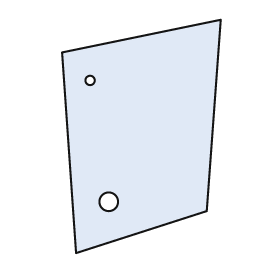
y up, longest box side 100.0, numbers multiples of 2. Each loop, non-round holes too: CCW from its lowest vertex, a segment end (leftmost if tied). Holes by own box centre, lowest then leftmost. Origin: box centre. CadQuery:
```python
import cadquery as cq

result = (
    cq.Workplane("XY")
    .moveTo(-28.0, -50.0)
    .lineTo(28.0, -32.0)
    .lineTo(34.0, 50.0)
    .lineTo(-34.0, 36.0)
    .close()
    .moveTo(-14.0, -28.0)
    .circle(4.0)
    .moveTo(-22.0, 24.0)
    .circle(2.0)
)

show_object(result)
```